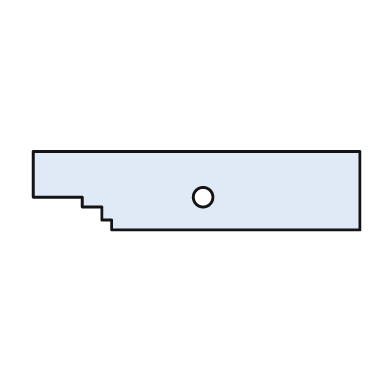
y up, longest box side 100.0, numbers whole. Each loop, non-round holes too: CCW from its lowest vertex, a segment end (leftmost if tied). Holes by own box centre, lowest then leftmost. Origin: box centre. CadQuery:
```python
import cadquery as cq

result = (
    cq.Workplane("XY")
    .moveTo(-26.0, -12.0)
    .lineTo(50.0, -12.0)
    .lineTo(50.0, 12.0)
    .lineTo(-50.0, 12.0)
    .lineTo(-50.0, -2.0)
    .lineTo(-35.0, -2.0)
    .lineTo(-35.0, -5.0)
    .lineTo(-29.0, -5.0)
    .lineTo(-29.0, -9.0)
    .lineTo(-26.0, -9.0)
    .close()
    .moveTo(2.0, -2.0)
    .circle(3.0)
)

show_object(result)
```